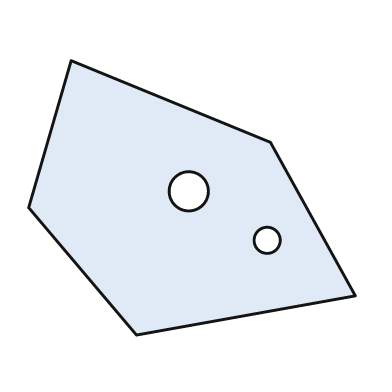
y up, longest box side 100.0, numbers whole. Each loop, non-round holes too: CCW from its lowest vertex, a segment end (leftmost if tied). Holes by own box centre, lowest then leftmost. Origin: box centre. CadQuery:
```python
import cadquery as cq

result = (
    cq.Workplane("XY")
    .moveTo(-17.0, -42.0)
    .lineTo(50.0, -30.0)
    .lineTo(24.0, 17.0)
    .lineTo(-37.0, 42.0)
    .lineTo(-50.0, -3.0)
    .close()
    .moveTo(23.0, -13.0)
    .circle(4.0)
    .moveTo(-1.0, 2.0)
    .circle(6.0)
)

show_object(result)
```